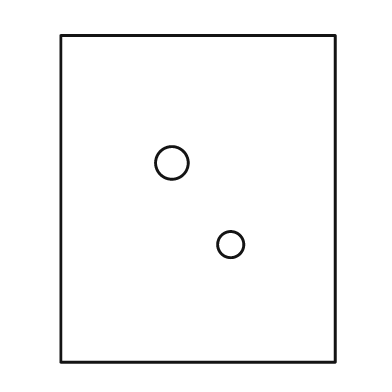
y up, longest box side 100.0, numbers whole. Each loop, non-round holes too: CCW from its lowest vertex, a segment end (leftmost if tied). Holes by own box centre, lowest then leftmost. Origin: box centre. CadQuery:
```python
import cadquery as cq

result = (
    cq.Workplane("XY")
    .moveTo(-42.0, -50.0)
    .lineTo(42.0, -50.0)
    .lineTo(42.0, 50.0)
    .lineTo(-42.0, 50.0)
    .close()
    .moveTo(10.0, -14.0)
    .circle(4.0)
    .moveTo(-8.0, 11.0)
    .circle(5.0)
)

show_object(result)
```